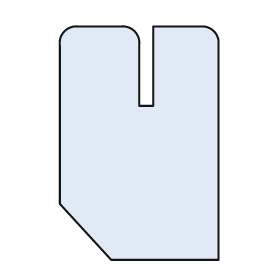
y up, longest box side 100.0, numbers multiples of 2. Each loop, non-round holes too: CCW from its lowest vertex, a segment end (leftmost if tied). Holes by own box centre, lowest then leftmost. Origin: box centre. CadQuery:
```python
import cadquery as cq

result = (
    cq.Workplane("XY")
    .moveTo(-12.0, -50.0)
    .lineTo(34.0, -50.0)
    .lineTo(34.0, 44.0)
    .threePointArc((32.0, 48.0), (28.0, 50.0))
    .lineTo(6.0, 50.0)
    .lineTo(6.0, 16.0)
    .lineTo(0.0, 16.0)
    .lineTo(0.0, 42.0)
    .threePointArc((-2.0, 48.0), (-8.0, 50.0))
    .lineTo(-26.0, 50.0)
    .threePointArc((-32.0, 48.0), (-34.0, 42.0))
    .lineTo(-34.0, -26.0)
    .close()
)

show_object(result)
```